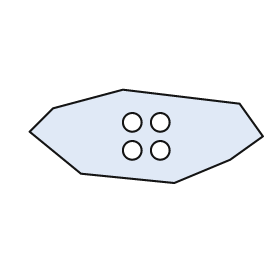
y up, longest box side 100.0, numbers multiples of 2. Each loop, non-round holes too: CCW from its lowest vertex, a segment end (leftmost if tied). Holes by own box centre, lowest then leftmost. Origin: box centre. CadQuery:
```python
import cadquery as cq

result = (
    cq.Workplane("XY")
    .moveTo(12.0, -20.0)
    .lineTo(36.0, -10.0)
    .lineTo(50.0, 0.0)
    .lineTo(40.0, 14.0)
    .lineTo(-10.0, 20.0)
    .lineTo(-40.0, 12.0)
    .lineTo(-50.0, 2.0)
    .lineTo(-28.0, -16.0)
    .close()
    .moveTo(-6.0, -6.0)
    .circle(4.0)
    .moveTo(6.0, -6.0)
    .circle(4.0)
    .moveTo(-6.0, 6.0)
    .circle(4.0)
    .moveTo(6.0, 6.0)
    .circle(4.0)
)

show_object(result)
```